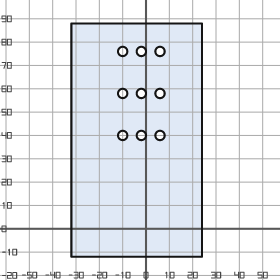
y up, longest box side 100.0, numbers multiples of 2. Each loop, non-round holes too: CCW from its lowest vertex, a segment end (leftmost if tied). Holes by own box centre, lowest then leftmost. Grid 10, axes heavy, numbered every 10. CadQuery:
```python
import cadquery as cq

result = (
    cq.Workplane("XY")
    .moveTo(-32.0, -12.0)
    .lineTo(24.0, -12.0)
    .lineTo(24.0, 88.0)
    .lineTo(-32.0, 88.0)
    .close()
    .moveTo(-10.0, 40.0)
    .circle(2.0)
    .moveTo(-2.0, 40.0)
    .circle(2.0)
    .moveTo(6.0, 40.0)
    .circle(2.0)
    .moveTo(-10.0, 58.0)
    .circle(2.0)
    .moveTo(-2.0, 58.0)
    .circle(2.0)
    .moveTo(6.0, 58.0)
    .circle(2.0)
    .moveTo(-10.0, 76.0)
    .circle(2.0)
    .moveTo(-2.0, 76.0)
    .circle(2.0)
    .moveTo(6.0, 76.0)
    .circle(2.0)
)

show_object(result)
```